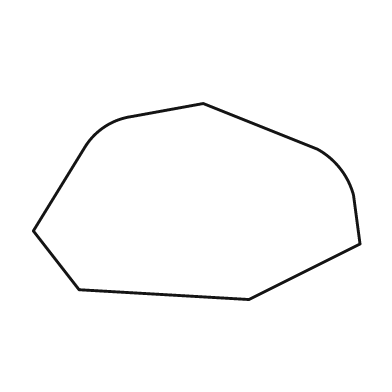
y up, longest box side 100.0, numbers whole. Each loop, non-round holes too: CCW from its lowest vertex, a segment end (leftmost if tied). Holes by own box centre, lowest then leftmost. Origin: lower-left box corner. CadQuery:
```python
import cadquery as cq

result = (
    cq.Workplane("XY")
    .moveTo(66.0, 0.0)
    .lineTo(100.0, 17.0)
    .lineTo(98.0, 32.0)
    .threePointArc((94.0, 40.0), (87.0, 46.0))
    .lineTo(52.0, 60.0)
    .lineTo(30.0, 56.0)
    .threePointArc((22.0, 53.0), (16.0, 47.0))
    .lineTo(0.0, 21.0)
    .lineTo(14.0, 3.0)
    .close()
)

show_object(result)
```